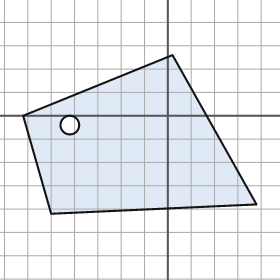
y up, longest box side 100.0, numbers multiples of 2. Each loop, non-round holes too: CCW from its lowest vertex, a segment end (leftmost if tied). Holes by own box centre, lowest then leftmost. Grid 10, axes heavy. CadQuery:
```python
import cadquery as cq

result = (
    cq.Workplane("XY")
    .moveTo(-50.0, -42.0)
    .lineTo(38.0, -38.0)
    .lineTo(2.0, 26.0)
    .lineTo(-62.0, 0.0)
    .close()
    .moveTo(-42.0, -4.0)
    .circle(4.0)
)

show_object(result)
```